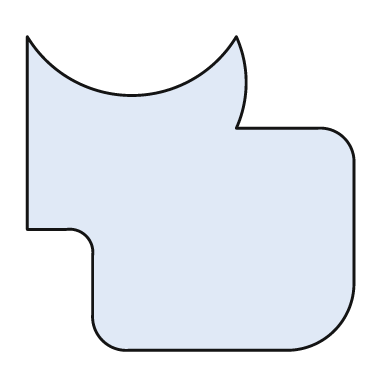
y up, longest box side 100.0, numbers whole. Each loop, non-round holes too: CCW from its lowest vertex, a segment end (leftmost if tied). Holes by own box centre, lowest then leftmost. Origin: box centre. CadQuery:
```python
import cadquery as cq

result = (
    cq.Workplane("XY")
    .moveTo(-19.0, -48.0)
    .lineTo(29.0, -48.0)
    .threePointArc((44.0, -42.0), (50.0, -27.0))
    .lineTo(50.0, 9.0)
    .threePointArc((47.0, 17.0), (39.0, 20.0))
    .lineTo(14.0, 20.0)
    .threePointArc((17.0, 34.0), (14.0, 48.0))
    .threePointArc((-18.0, 30.0), (-50.0, 48.0))
    .lineTo(-50.0, -11.0)
    .lineTo(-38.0, -11.0)
    .threePointArc((-32.0, -13.0), (-30.0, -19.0))
    .lineTo(-30.0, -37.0)
    .threePointArc((-27.0, -45.0), (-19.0, -48.0))
    .close()
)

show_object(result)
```